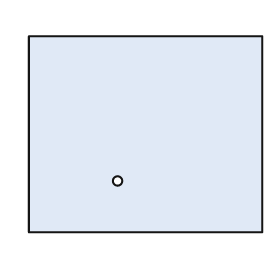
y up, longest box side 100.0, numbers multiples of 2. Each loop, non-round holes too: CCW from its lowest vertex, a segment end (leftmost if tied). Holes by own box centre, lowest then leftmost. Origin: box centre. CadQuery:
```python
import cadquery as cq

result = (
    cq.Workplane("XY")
    .moveTo(-50.0, -42.0)
    .lineTo(50.0, -42.0)
    .lineTo(50.0, 42.0)
    .lineTo(-50.0, 42.0)
    .close()
    .moveTo(-12.0, -20.0)
    .circle(2.0)
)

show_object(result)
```